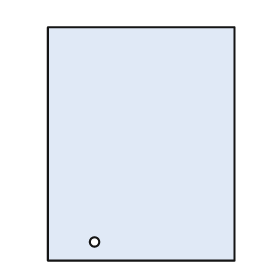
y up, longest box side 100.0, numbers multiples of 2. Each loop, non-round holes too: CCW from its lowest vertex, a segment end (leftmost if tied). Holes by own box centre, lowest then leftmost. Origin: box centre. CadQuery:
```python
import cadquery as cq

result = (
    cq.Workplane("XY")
    .moveTo(-40.0, -50.0)
    .lineTo(40.0, -50.0)
    .lineTo(40.0, 50.0)
    .lineTo(-40.0, 50.0)
    .close()
    .moveTo(-20.0, -42.0)
    .circle(2.0)
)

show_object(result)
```